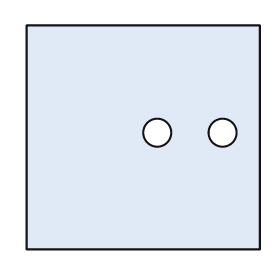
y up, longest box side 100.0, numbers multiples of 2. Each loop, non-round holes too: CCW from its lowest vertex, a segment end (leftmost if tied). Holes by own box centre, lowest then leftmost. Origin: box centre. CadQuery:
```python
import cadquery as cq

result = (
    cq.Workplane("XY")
    .moveTo(-50.0, -48.0)
    .lineTo(50.0, -48.0)
    .lineTo(50.0, 48.0)
    .lineTo(-50.0, 48.0)
    .close()
    .moveTo(6.0, 2.0)
    .circle(6.0)
    .moveTo(34.0, 2.0)
    .circle(6.0)
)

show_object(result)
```